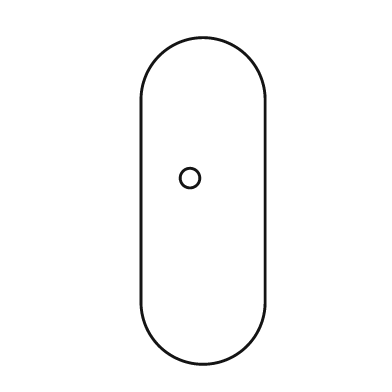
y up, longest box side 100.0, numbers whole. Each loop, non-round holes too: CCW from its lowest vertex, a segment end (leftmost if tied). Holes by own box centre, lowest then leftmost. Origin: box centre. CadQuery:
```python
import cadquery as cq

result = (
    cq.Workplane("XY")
    .moveTo(-19.0, -31.0)
    .threePointArc((0.0, -50.0), (19.0, -31.0))
    .lineTo(19.0, 31.0)
    .threePointArc((0.0, 50.0), (-19.0, 31.0))
    .close()
    .moveTo(-4.0, 7.0)
    .circle(3.0)
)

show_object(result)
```